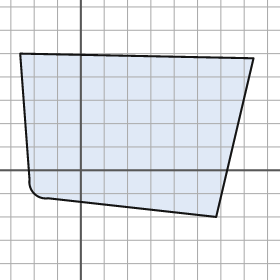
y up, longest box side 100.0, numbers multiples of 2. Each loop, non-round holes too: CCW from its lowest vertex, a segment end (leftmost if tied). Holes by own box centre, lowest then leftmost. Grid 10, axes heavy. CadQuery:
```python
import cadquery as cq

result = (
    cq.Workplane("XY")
    .moveTo(58.0, -20.0)
    .lineTo(74.0, 48.0)
    .lineTo(-26.0, 50.0)
    .lineTo(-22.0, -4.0)
    .threePointArc((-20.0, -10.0), (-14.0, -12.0))
    .close()
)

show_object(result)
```